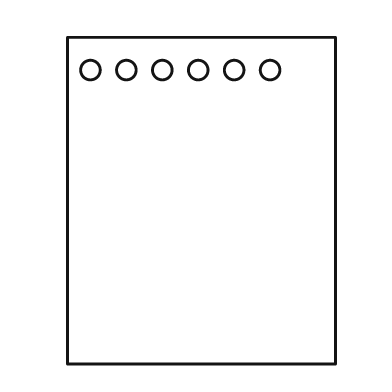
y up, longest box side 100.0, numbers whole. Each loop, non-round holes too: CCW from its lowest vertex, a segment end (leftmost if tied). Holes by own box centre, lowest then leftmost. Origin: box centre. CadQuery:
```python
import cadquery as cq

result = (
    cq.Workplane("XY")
    .moveTo(-41.0, -50.0)
    .lineTo(41.0, -50.0)
    .lineTo(41.0, 50.0)
    .lineTo(-41.0, 50.0)
    .close()
    .moveTo(-34.0, 40.0)
    .circle(3.0)
    .moveTo(-23.0, 40.0)
    .circle(3.0)
    .moveTo(-12.0, 40.0)
    .circle(3.0)
    .moveTo(-1.0, 40.0)
    .circle(3.0)
    .moveTo(10.0, 40.0)
    .circle(3.0)
    .moveTo(21.0, 40.0)
    .circle(3.0)
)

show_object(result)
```